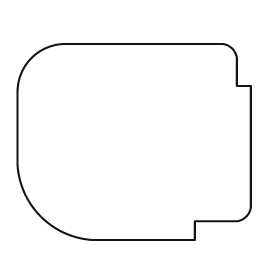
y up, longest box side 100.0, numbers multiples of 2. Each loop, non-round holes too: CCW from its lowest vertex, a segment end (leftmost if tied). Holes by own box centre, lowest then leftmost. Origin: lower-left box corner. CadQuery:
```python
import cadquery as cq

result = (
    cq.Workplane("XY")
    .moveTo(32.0, 0.0)
    .lineTo(76.0, 0.0)
    .lineTo(76.0, 8.0)
    .lineTo(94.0, 8.0)
    .threePointArc((98.0, 10.0), (100.0, 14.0))
    .lineTo(100.0, 66.0)
    .lineTo(94.0, 66.0)
    .lineTo(94.0, 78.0)
    .threePointArc((92.0, 82.0), (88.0, 84.0))
    .lineTo(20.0, 84.0)
    .threePointArc((6.0, 78.0), (0.0, 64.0))
    .lineTo(0.0, 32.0)
    .threePointArc((10.0, 10.0), (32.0, 0.0))
    .close()
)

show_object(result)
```